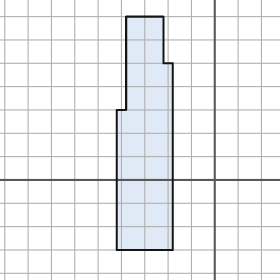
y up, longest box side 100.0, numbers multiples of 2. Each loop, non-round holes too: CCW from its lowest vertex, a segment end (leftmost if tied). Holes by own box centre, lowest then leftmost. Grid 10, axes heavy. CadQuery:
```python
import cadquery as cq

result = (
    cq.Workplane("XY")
    .moveTo(-42.0, -30.0)
    .lineTo(-18.0, -30.0)
    .lineTo(-18.0, 50.0)
    .lineTo(-22.0, 50.0)
    .lineTo(-22.0, 70.0)
    .lineTo(-38.0, 70.0)
    .lineTo(-38.0, 30.0)
    .lineTo(-42.0, 30.0)
    .close()
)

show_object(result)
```